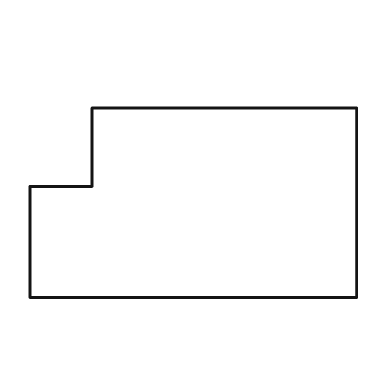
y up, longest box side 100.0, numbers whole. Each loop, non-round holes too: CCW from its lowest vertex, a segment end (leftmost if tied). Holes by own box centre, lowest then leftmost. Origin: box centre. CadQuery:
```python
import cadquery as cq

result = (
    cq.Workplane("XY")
    .moveTo(-50.0, -29.0)
    .lineTo(50.0, -29.0)
    .lineTo(50.0, 29.0)
    .lineTo(-31.0, 29.0)
    .lineTo(-31.0, 5.0)
    .lineTo(-50.0, 5.0)
    .close()
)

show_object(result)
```